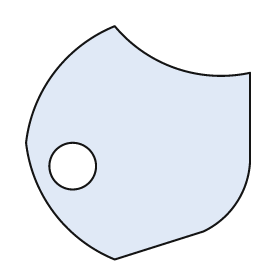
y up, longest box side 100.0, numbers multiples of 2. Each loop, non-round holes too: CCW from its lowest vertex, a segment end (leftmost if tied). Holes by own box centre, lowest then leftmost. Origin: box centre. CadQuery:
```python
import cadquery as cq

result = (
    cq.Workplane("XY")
    .moveTo(-10.0, -50.0)
    .lineTo(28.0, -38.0)
    .threePointArc((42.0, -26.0), (48.0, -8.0))
    .lineTo(48.0, 30.0)
    .threePointArc((16.0, 32.0), (-10.0, 50.0))
    .threePointArc((-36.0, 30.0), (-48.0, 0.0))
    .threePointArc((-36.0, -30.0), (-10.0, -50.0))
    .close()
    .moveTo(-28.0, -10.0)
    .circle(10.0)
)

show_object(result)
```